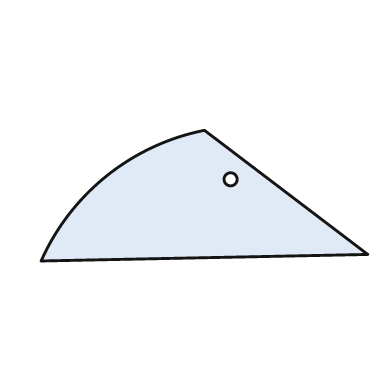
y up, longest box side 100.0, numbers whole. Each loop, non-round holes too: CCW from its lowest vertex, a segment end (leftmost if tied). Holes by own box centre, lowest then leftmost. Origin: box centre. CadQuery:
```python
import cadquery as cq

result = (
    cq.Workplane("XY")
    .moveTo(-50.0, -20.0)
    .lineTo(50.0, -18.0)
    .lineTo(0.0, 20.0)
    .threePointArc((-30.0, 6.0), (-50.0, -20.0))
    .close()
    .moveTo(8.0, 5.0)
    .circle(2.0)
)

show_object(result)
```